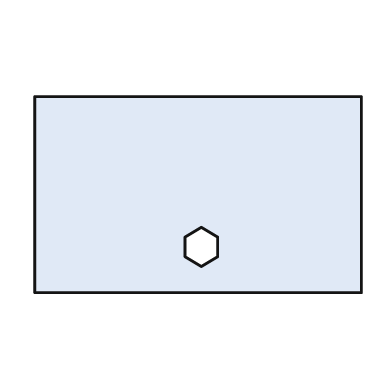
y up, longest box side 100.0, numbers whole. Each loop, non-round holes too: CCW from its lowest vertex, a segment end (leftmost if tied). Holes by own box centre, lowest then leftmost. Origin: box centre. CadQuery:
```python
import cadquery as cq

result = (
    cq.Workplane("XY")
    .moveTo(-50.0, -30.0)
    .lineTo(50.0, -30.0)
    .lineTo(50.0, 30.0)
    .lineTo(-50.0, 30.0)
    .close()
    .moveTo(1.0, -22.0)
    .lineTo(6.0, -19.0)
    .lineTo(6.0, -13.0)
    .lineTo(1.0, -10.0)
    .lineTo(-4.0, -13.0)
    .lineTo(-4.0, -19.0)
    .close()
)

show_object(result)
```